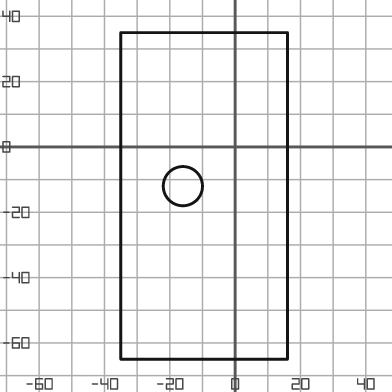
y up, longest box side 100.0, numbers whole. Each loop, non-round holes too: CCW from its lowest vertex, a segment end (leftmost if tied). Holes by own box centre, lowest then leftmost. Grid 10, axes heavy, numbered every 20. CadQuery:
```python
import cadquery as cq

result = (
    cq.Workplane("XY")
    .moveTo(-35.0, -65.0)
    .lineTo(16.0, -65.0)
    .lineTo(16.0, 35.0)
    .lineTo(-35.0, 35.0)
    .close()
    .moveTo(-16.0, -12.0)
    .circle(6.0)
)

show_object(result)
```